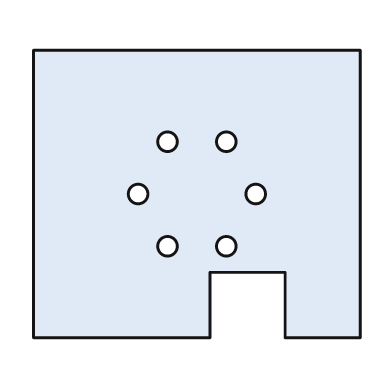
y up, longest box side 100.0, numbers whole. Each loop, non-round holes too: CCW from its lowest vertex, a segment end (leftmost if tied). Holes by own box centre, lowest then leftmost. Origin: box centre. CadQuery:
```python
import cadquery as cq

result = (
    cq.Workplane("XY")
    .moveTo(-50.0, -44.0)
    .lineTo(4.0, -44.0)
    .lineTo(4.0, -24.0)
    .lineTo(27.0, -24.0)
    .lineTo(27.0, -44.0)
    .lineTo(50.0, -44.0)
    .lineTo(50.0, 44.0)
    .lineTo(-50.0, 44.0)
    .close()
    .moveTo(-9.0, -16.0)
    .circle(3.0)
    .moveTo(9.0, -16.0)
    .circle(3.0)
    .moveTo(-18.0, 0.0)
    .circle(3.0)
    .moveTo(18.0, 0.0)
    .circle(3.0)
    .moveTo(-9.0, 16.0)
    .circle(3.0)
    .moveTo(9.0, 16.0)
    .circle(3.0)
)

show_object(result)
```